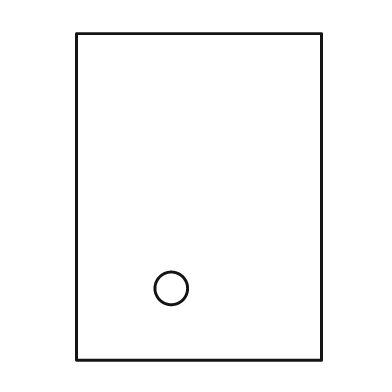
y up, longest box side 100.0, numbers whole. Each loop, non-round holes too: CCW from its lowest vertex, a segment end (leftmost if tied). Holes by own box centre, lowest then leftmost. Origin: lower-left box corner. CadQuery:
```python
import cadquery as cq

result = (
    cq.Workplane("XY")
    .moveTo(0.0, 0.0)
    .lineTo(75.0, 0.0)
    .lineTo(75.0, 100.0)
    .lineTo(0.0, 100.0)
    .close()
    .moveTo(29.0, 22.0)
    .circle(5.0)
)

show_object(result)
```